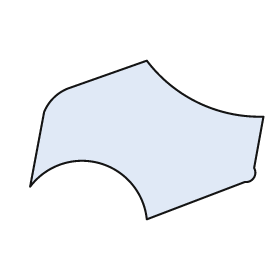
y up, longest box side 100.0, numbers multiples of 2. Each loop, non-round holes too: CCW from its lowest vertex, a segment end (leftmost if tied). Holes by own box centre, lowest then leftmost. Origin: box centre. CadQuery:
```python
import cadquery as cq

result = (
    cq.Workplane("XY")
    .moveTo(0.0, -34.0)
    .lineTo(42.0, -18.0)
    .threePointArc((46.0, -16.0), (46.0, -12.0))
    .lineTo(50.0, 10.0)
    .threePointArc((22.0, 16.0), (0.0, 34.0))
    .lineTo(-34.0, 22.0)
    .threePointArc((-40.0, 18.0), (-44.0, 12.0))
    .lineTo(-50.0, -20.0)
    .threePointArc((-20.0, -10.0), (0.0, -34.0))
    .close()
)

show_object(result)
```